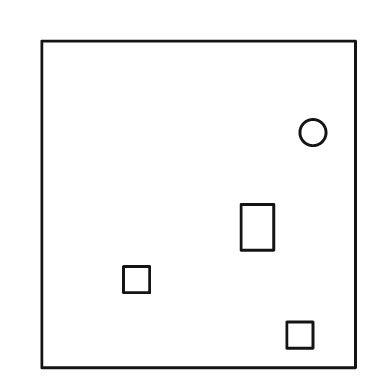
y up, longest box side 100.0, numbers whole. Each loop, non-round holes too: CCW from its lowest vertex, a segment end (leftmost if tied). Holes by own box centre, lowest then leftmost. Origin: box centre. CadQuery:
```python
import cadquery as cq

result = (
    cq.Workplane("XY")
    .moveTo(-48.0, -50.0)
    .lineTo(48.0, -50.0)
    .lineTo(48.0, 50.0)
    .lineTo(-48.0, 50.0)
    .close()
    .moveTo(27.0, -44.0)
    .lineTo(35.0, -44.0)
    .lineTo(35.0, -36.0)
    .lineTo(27.0, -36.0)
    .close()
    .moveTo(-23.0, -27.0)
    .lineTo(-15.0, -27.0)
    .lineTo(-15.0, -19.0)
    .lineTo(-23.0, -19.0)
    .close()
    .moveTo(13.0, -14.0)
    .lineTo(23.0, -14.0)
    .lineTo(23.0, 0.0)
    .lineTo(13.0, 0.0)
    .close()
    .moveTo(35.0, 22.0)
    .circle(4.0)
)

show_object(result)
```